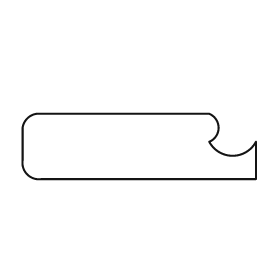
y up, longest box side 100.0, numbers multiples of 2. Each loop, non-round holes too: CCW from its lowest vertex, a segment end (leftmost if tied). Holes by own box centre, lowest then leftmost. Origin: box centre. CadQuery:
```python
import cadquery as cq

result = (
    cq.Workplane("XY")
    .moveTo(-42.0, -14.0)
    .lineTo(50.0, -14.0)
    .lineTo(50.0, 2.0)
    .threePointArc((40.0, -4.0), (30.0, 2.0))
    .threePointArc((34.0, 8.0), (30.0, 14.0))
    .lineTo(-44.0, 14.0)
    .threePointArc((-48.0, 12.0), (-50.0, 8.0))
    .lineTo(-50.0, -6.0)
    .threePointArc((-48.0, -12.0), (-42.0, -14.0))
    .close()
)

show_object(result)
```